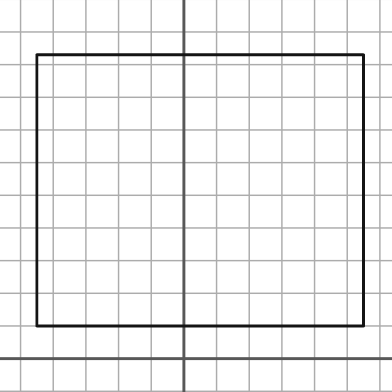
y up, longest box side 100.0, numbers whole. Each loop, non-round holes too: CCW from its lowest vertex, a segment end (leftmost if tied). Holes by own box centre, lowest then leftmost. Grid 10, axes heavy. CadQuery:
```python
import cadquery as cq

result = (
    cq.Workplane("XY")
    .moveTo(-45.0, 10.0)
    .lineTo(55.0, 10.0)
    .lineTo(55.0, 93.0)
    .lineTo(-45.0, 93.0)
    .close()
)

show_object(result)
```